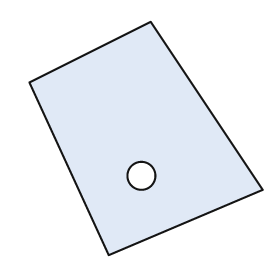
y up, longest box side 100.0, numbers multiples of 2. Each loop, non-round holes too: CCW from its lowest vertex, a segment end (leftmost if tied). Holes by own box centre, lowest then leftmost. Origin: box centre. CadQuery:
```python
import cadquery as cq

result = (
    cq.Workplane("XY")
    .moveTo(-16.0, -50.0)
    .lineTo(50.0, -22.0)
    .lineTo(2.0, 50.0)
    .lineTo(-50.0, 24.0)
    .close()
    .moveTo(-2.0, -16.0)
    .circle(6.0)
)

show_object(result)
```